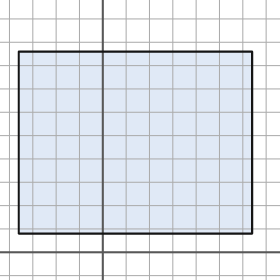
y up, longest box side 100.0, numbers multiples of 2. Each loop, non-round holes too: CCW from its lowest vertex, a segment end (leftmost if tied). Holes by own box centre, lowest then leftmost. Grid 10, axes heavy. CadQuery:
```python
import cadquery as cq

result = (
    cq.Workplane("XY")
    .moveTo(-36.0, 8.0)
    .lineTo(64.0, 8.0)
    .lineTo(64.0, 86.0)
    .lineTo(-36.0, 86.0)
    .close()
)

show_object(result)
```